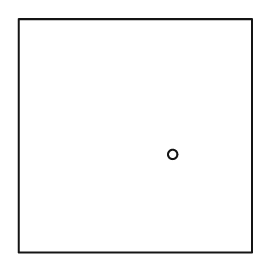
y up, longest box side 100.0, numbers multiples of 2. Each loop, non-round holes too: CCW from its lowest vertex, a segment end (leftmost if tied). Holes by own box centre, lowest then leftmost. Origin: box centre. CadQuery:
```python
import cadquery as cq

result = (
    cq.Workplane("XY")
    .moveTo(-50.0, -50.0)
    .lineTo(50.0, -50.0)
    .lineTo(50.0, 50.0)
    .lineTo(-50.0, 50.0)
    .close()
    .moveTo(16.0, -8.0)
    .circle(2.0)
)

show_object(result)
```